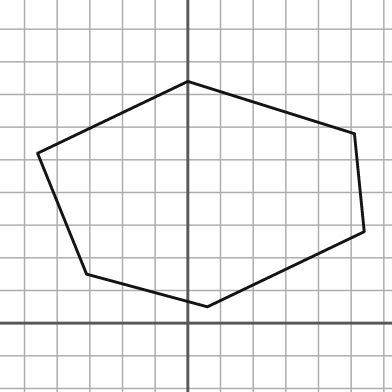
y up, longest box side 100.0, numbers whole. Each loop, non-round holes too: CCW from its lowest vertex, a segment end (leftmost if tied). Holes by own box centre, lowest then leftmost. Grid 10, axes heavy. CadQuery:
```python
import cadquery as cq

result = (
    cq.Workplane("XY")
    .moveTo(6.0, 5.0)
    .lineTo(54.0, 28.0)
    .lineTo(51.0, 58.0)
    .lineTo(0.0, 74.0)
    .lineTo(-46.0, 52.0)
    .lineTo(-31.0, 15.0)
    .close()
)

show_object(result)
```